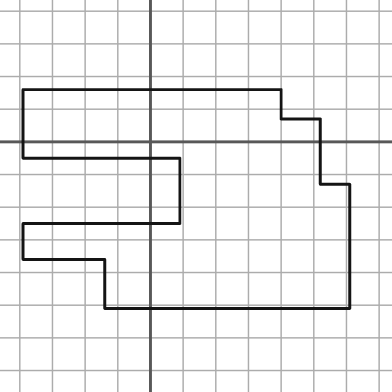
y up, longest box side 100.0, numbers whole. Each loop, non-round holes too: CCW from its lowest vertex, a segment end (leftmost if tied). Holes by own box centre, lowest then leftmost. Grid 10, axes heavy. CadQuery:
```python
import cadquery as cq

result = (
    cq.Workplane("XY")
    .moveTo(-14.0, -51.0)
    .lineTo(61.0, -51.0)
    .lineTo(61.0, -13.0)
    .lineTo(52.0, -13.0)
    .lineTo(52.0, 7.0)
    .lineTo(40.0, 7.0)
    .lineTo(40.0, 16.0)
    .lineTo(-39.0, 16.0)
    .lineTo(-39.0, -5.0)
    .lineTo(9.0, -5.0)
    .lineTo(9.0, -25.0)
    .lineTo(-39.0, -25.0)
    .lineTo(-39.0, -36.0)
    .lineTo(-14.0, -36.0)
    .close()
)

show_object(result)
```